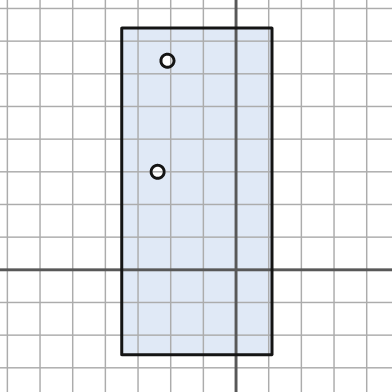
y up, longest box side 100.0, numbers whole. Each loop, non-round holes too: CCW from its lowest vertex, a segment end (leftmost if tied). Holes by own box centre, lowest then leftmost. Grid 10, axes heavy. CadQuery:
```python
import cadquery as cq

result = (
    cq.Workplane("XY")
    .moveTo(-35.0, -26.0)
    .lineTo(11.0, -26.0)
    .lineTo(11.0, 74.0)
    .lineTo(-35.0, 74.0)
    .close()
    .moveTo(-24.0, 30.0)
    .circle(2.0)
    .moveTo(-21.0, 64.0)
    .circle(2.0)
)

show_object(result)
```